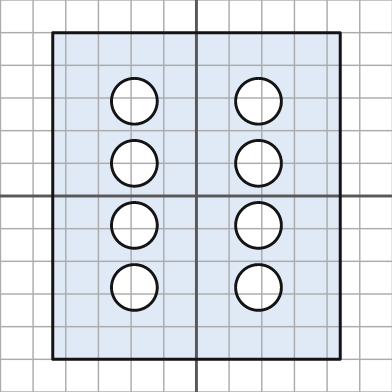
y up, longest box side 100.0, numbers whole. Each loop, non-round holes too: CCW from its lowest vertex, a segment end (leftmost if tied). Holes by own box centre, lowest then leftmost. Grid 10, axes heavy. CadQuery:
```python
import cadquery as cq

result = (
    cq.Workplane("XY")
    .moveTo(-44.0, -50.0)
    .lineTo(44.0, -50.0)
    .lineTo(44.0, 50.0)
    .lineTo(-44.0, 50.0)
    .close()
    .moveTo(-19.0, -28.0)
    .circle(7.0)
    .moveTo(19.0, -28.0)
    .circle(7.0)
    .moveTo(-19.0, -9.0)
    .circle(7.0)
    .moveTo(19.0, -9.0)
    .circle(7.0)
    .moveTo(-19.0, 10.0)
    .circle(7.0)
    .moveTo(19.0, 10.0)
    .circle(7.0)
    .moveTo(-19.0, 29.0)
    .circle(7.0)
    .moveTo(19.0, 29.0)
    .circle(7.0)
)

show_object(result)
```